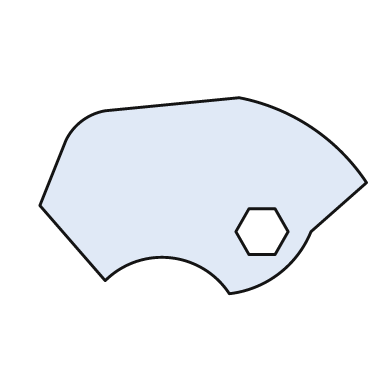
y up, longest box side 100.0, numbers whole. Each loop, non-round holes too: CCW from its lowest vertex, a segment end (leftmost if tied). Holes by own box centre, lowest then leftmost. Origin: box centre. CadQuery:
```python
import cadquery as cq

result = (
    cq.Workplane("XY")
    .moveTo(8.0, -30.0)
    .threePointArc((23.0, -24.0), (33.0, -11.0))
    .lineTo(50.0, 4.0)
    .threePointArc((33.0, 21.0), (11.0, 30.0))
    .lineTo(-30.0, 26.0)
    .threePointArc((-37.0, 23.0), (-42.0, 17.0))
    .lineTo(-50.0, -3.0)
    .lineTo(-30.0, -26.0)
    .threePointArc((-10.0, -19.0), (8.0, -30.0))
    .close()
    .moveTo(14.0, -18.0)
    .lineTo(22.0, -18.0)
    .lineTo(26.0, -11.0)
    .lineTo(22.0, -4.0)
    .lineTo(14.0, -4.0)
    .lineTo(10.0, -11.0)
    .close()
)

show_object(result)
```